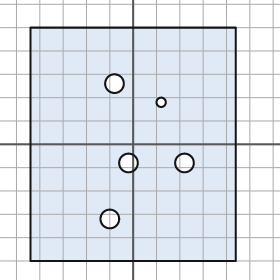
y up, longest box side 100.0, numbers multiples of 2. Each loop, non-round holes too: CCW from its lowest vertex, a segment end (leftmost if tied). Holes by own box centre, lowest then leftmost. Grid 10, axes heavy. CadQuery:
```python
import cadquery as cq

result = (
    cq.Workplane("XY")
    .moveTo(-44.0, -50.0)
    .lineTo(44.0, -50.0)
    .lineTo(44.0, 50.0)
    .lineTo(-44.0, 50.0)
    .close()
    .moveTo(-10.0, -32.0)
    .circle(4.0)
    .moveTo(-2.0, -8.0)
    .circle(4.0)
    .moveTo(22.0, -8.0)
    .circle(4.0)
    .moveTo(12.0, 18.0)
    .circle(2.0)
    .moveTo(-8.0, 26.0)
    .circle(4.0)
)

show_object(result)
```